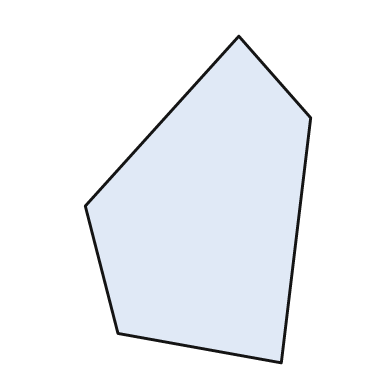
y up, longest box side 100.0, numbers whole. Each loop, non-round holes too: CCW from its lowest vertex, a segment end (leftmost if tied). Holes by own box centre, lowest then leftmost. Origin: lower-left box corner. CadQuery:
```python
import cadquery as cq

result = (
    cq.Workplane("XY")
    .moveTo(60.0, 0.0)
    .lineTo(69.0, 75.0)
    .lineTo(47.0, 100.0)
    .lineTo(0.0, 48.0)
    .lineTo(10.0, 9.0)
    .close()
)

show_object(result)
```